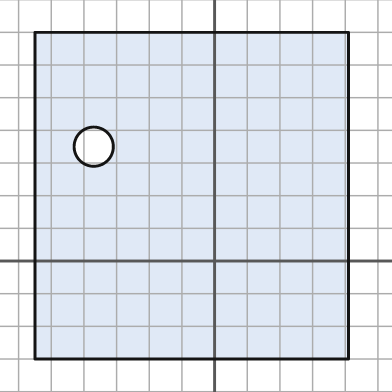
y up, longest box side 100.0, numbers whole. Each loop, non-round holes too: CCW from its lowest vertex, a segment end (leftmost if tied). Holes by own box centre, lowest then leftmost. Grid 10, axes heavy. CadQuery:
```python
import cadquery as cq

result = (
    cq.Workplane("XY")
    .moveTo(-55.0, -30.0)
    .lineTo(41.0, -30.0)
    .lineTo(41.0, 70.0)
    .lineTo(-55.0, 70.0)
    .close()
    .moveTo(-37.0, 35.0)
    .circle(6.0)
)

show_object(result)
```